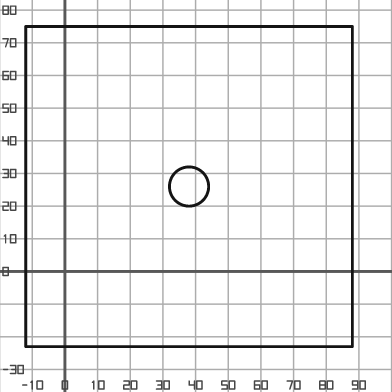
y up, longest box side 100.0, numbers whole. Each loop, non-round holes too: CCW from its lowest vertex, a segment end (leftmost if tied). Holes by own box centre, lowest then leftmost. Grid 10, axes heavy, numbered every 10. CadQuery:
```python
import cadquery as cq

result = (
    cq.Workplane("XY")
    .moveTo(-12.0, -23.0)
    .lineTo(88.0, -23.0)
    .lineTo(88.0, 75.0)
    .lineTo(-12.0, 75.0)
    .close()
    .moveTo(38.0, 26.0)
    .circle(6.0)
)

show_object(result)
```